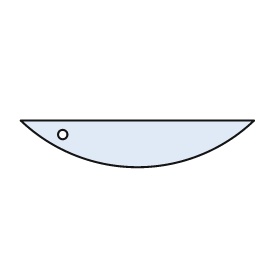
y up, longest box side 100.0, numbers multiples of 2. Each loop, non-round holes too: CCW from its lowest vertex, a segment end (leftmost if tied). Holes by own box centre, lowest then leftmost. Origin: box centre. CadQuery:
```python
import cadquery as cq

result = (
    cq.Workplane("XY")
    .moveTo(-50.0, 10.0)
    .threePointArc((0.0, -10.0), (50.0, 10.0))
    .close()
    .moveTo(-32.0, 4.0)
    .circle(2.0)
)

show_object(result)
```